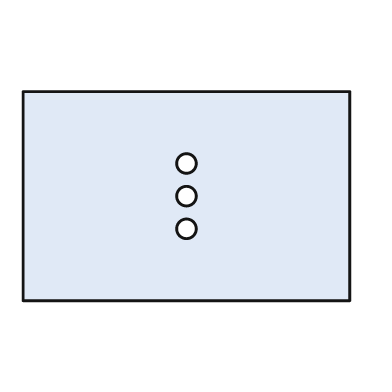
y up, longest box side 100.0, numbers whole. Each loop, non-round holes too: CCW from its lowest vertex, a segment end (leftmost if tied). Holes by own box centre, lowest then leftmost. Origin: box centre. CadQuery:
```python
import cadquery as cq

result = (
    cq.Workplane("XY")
    .moveTo(-50.0, -32.0)
    .lineTo(50.0, -32.0)
    .lineTo(50.0, 32.0)
    .lineTo(-50.0, 32.0)
    .close()
    .moveTo(0.0, -10.0)
    .circle(3.0)
    .moveTo(0.0, 0.0)
    .circle(3.0)
    .moveTo(0.0, 10.0)
    .circle(3.0)
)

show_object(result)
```